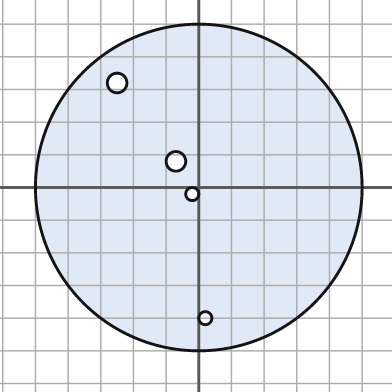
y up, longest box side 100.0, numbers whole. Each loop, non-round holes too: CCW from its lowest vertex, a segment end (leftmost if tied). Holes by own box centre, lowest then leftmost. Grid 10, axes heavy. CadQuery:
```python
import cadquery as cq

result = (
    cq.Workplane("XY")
    .moveTo(0.0, 0.0)
    .circle(50.0)
    .moveTo(2.0, -40.0)
    .circle(2.0)
    .moveTo(-2.0, -2.0)
    .circle(2.0)
    .moveTo(-7.0, 8.0)
    .circle(3.0)
    .moveTo(-25.0, 32.0)
    .circle(3.0)
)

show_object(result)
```